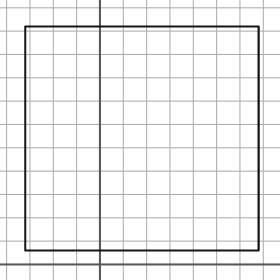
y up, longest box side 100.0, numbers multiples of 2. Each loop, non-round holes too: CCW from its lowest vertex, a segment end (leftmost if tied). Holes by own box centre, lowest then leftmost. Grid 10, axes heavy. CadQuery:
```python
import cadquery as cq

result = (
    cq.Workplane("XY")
    .moveTo(-32.0, 6.0)
    .lineTo(68.0, 6.0)
    .lineTo(68.0, 102.0)
    .lineTo(-32.0, 102.0)
    .close()
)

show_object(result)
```